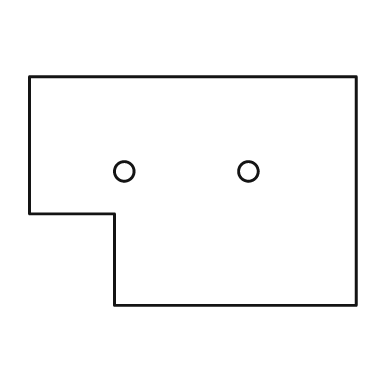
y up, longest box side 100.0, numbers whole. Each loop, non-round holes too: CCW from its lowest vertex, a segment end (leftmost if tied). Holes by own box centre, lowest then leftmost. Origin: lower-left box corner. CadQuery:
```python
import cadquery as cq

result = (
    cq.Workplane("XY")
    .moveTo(26.0, 0.0)
    .lineTo(100.0, 0.0)
    .lineTo(100.0, 70.0)
    .lineTo(0.0, 70.0)
    .lineTo(0.0, 28.0)
    .lineTo(26.0, 28.0)
    .close()
    .moveTo(29.0, 41.0)
    .circle(3.0)
    .moveTo(67.0, 41.0)
    .circle(3.0)
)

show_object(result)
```